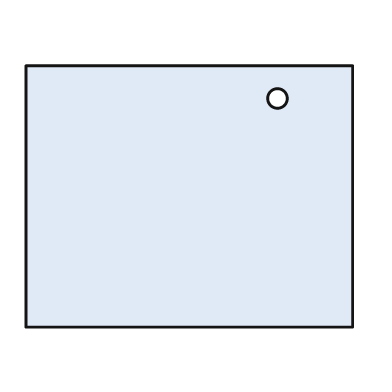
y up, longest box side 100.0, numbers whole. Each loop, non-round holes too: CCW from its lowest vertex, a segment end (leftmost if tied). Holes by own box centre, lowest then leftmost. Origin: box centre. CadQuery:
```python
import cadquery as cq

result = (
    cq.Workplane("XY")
    .moveTo(-50.0, -40.0)
    .lineTo(50.0, -40.0)
    .lineTo(50.0, 40.0)
    .lineTo(-50.0, 40.0)
    .close()
    .moveTo(27.0, 30.0)
    .circle(3.0)
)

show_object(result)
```